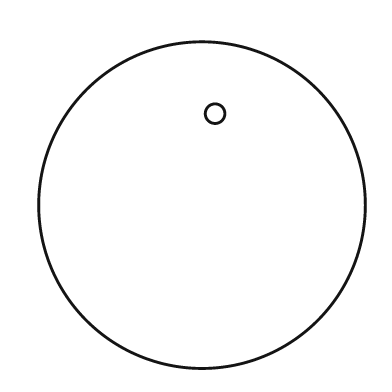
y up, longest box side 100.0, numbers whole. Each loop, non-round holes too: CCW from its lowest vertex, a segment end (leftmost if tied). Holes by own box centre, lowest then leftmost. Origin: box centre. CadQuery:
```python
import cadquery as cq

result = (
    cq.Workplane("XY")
    .moveTo(0.0, 0.0)
    .circle(50.0)
    .moveTo(4.0, 28.0)
    .circle(3.0)
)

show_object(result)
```